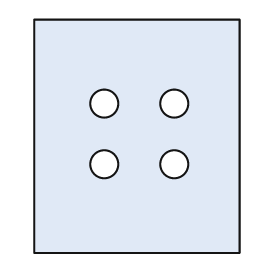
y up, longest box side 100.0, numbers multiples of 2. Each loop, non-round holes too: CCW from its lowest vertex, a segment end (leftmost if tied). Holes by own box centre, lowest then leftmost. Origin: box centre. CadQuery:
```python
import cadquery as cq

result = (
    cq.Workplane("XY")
    .moveTo(-44.0, -50.0)
    .lineTo(44.0, -50.0)
    .lineTo(44.0, 50.0)
    .lineTo(-44.0, 50.0)
    .close()
    .moveTo(-14.0, -12.0)
    .circle(6.0)
    .moveTo(16.0, -12.0)
    .circle(6.0)
    .moveTo(-14.0, 14.0)
    .circle(6.0)
    .moveTo(16.0, 14.0)
    .circle(6.0)
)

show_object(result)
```